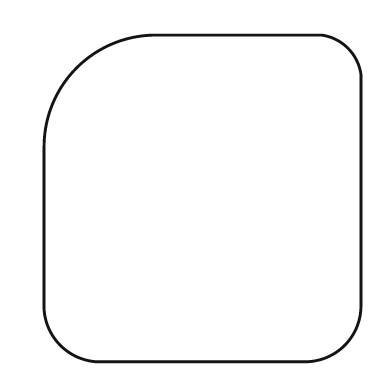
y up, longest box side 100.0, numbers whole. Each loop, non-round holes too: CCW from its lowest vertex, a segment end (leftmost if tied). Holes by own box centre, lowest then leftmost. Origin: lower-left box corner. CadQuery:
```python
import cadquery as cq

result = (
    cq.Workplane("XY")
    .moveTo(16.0, 0.0)
    .lineTo(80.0, 0.0)
    .threePointArc((92.0, 5.0), (97.0, 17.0))
    .lineTo(97.0, 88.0)
    .threePointArc((93.0, 96.0), (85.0, 100.0))
    .lineTo(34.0, 100.0)
    .threePointArc((10.0, 90.0), (0.0, 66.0))
    .lineTo(0.0, 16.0)
    .threePointArc((5.0, 5.0), (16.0, 0.0))
    .close()
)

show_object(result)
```